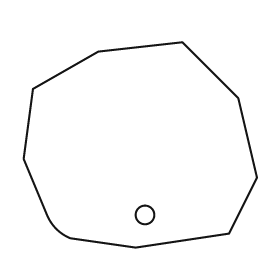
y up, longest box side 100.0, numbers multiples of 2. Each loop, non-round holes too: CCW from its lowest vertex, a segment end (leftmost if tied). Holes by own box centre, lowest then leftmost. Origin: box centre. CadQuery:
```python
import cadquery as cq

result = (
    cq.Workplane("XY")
    .moveTo(-2.0, -44.0)
    .lineTo(38.0, -38.0)
    .lineTo(50.0, -14.0)
    .lineTo(42.0, 20.0)
    .lineTo(18.0, 44.0)
    .lineTo(-18.0, 40.0)
    .lineTo(-46.0, 24.0)
    .lineTo(-50.0, -6.0)
    .lineTo(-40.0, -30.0)
    .threePointArc((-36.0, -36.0), (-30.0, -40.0))
    .close()
    .moveTo(2.0, -30.0)
    .circle(4.0)
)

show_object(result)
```